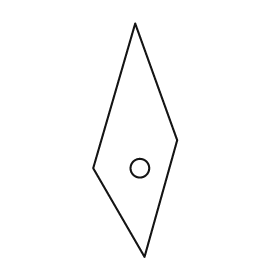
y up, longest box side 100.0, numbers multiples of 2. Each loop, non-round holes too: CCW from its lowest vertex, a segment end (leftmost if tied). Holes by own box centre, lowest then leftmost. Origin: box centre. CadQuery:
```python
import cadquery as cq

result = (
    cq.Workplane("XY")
    .moveTo(4.0, -50.0)
    .lineTo(18.0, 0.0)
    .lineTo(0.0, 50.0)
    .lineTo(-18.0, -12.0)
    .close()
    .moveTo(2.0, -12.0)
    .circle(4.0)
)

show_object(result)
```